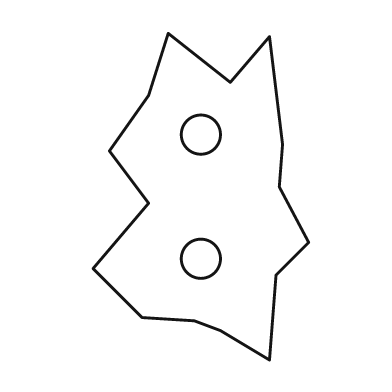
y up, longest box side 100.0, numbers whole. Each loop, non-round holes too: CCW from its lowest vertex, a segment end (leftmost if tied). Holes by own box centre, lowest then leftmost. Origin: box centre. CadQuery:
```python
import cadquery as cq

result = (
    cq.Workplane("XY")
    .moveTo(21.0, -50.0)
    .lineTo(23.0, -24.0)
    .lineTo(33.0, -14.0)
    .lineTo(24.0, 3.0)
    .lineTo(25.0, 16.0)
    .lineTo(21.0, 49.0)
    .lineTo(9.0, 35.0)
    .lineTo(-10.0, 50.0)
    .lineTo(-16.0, 31.0)
    .lineTo(-28.0, 14.0)
    .lineTo(-16.0, -2.0)
    .lineTo(-33.0, -22.0)
    .lineTo(-18.0, -37.0)
    .lineTo(-2.0, -38.0)
    .lineTo(6.0, -41.0)
    .close()
    .moveTo(0.0, -19.0)
    .circle(6.0)
    .moveTo(0.0, 19.0)
    .circle(6.0)
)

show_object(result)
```